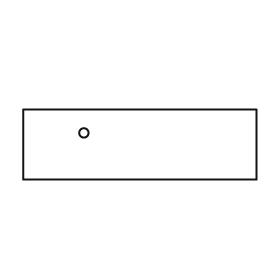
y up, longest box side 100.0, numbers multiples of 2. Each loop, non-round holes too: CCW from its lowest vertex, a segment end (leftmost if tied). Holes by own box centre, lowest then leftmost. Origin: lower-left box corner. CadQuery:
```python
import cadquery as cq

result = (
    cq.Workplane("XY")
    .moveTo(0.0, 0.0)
    .lineTo(100.0, 0.0)
    .lineTo(100.0, 30.0)
    .lineTo(0.0, 30.0)
    .close()
    .moveTo(26.0, 20.0)
    .circle(2.0)
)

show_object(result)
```